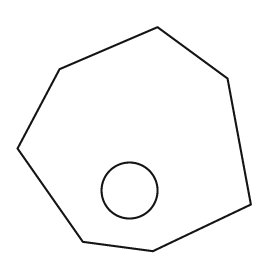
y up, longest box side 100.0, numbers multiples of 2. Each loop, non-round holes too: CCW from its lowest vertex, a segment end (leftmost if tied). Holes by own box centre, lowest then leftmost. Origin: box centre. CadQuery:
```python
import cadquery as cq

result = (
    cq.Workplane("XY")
    .moveTo(8.0, -48.0)
    .lineTo(50.0, -28.0)
    .lineTo(40.0, 26.0)
    .lineTo(10.0, 48.0)
    .lineTo(-32.0, 30.0)
    .lineTo(-50.0, -4.0)
    .lineTo(-22.0, -44.0)
    .close()
    .moveTo(-2.0, -22.0)
    .circle(12.0)
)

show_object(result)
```